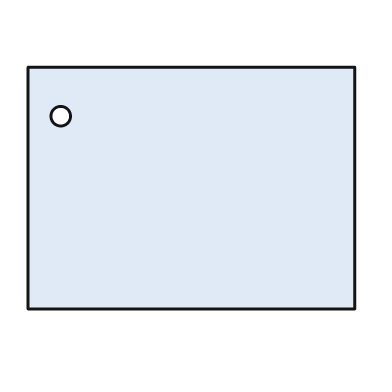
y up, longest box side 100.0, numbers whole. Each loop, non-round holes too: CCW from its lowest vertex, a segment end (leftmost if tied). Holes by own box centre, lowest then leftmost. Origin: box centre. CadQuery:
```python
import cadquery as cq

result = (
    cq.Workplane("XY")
    .moveTo(-50.0, -37.0)
    .lineTo(50.0, -37.0)
    .lineTo(50.0, 37.0)
    .lineTo(-50.0, 37.0)
    .close()
    .moveTo(-40.0, 22.0)
    .circle(3.0)
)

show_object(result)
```